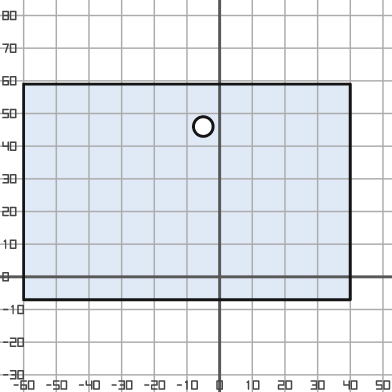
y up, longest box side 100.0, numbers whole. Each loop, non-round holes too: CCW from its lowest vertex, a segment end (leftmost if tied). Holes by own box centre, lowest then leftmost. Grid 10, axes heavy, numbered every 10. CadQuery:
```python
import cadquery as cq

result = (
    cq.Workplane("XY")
    .moveTo(-60.0, -7.0)
    .lineTo(40.0, -7.0)
    .lineTo(40.0, 59.0)
    .lineTo(-60.0, 59.0)
    .close()
    .moveTo(-5.0, 46.0)
    .circle(3.0)
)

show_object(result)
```